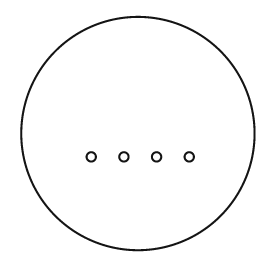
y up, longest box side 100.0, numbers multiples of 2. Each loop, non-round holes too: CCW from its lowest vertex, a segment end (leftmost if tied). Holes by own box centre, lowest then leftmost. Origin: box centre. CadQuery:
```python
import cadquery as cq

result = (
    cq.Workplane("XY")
    .moveTo(0.0, 0.0)
    .circle(50.0)
    .moveTo(-20.0, -10.0)
    .circle(2.0)
    .moveTo(-6.0, -10.0)
    .circle(2.0)
    .moveTo(8.0, -10.0)
    .circle(2.0)
    .moveTo(22.0, -10.0)
    .circle(2.0)
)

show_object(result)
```